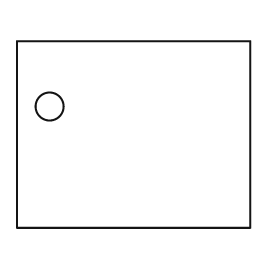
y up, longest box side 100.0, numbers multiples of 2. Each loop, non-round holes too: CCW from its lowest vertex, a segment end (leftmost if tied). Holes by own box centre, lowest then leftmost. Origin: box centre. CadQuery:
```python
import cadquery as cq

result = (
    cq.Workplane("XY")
    .moveTo(-50.0, -40.0)
    .lineTo(50.0, -40.0)
    .lineTo(50.0, 40.0)
    .lineTo(-50.0, 40.0)
    .close()
    .moveTo(-36.0, 12.0)
    .circle(6.0)
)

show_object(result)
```